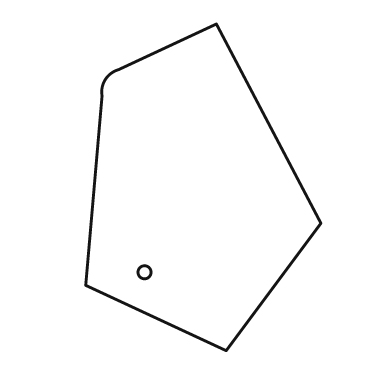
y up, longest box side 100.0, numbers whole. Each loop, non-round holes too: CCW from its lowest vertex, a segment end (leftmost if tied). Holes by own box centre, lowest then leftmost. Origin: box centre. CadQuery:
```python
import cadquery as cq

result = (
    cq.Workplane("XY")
    .moveTo(7.0, -50.0)
    .lineTo(36.0, -11.0)
    .lineTo(4.0, 50.0)
    .lineTo(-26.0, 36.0)
    .threePointArc((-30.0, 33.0), (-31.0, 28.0))
    .lineTo(-36.0, -30.0)
    .close()
    .moveTo(-18.0, -26.0)
    .circle(2.0)
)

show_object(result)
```